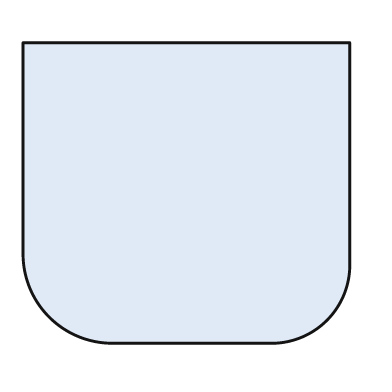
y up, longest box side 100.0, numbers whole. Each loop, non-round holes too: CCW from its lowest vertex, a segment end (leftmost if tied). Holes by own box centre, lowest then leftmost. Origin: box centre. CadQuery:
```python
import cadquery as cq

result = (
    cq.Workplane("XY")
    .moveTo(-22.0, -46.0)
    .lineTo(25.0, -46.0)
    .threePointArc((43.0, -39.0), (50.0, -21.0))
    .lineTo(50.0, 46.0)
    .lineTo(-50.0, 46.0)
    .lineTo(-50.0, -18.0)
    .threePointArc((-42.0, -38.0), (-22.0, -46.0))
    .close()
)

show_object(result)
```